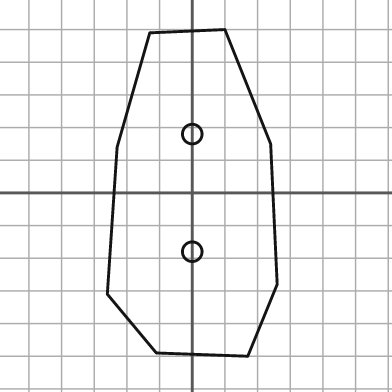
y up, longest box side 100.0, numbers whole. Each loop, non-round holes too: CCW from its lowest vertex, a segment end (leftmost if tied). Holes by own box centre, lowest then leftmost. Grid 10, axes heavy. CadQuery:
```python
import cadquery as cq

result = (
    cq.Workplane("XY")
    .moveTo(17.0, -50.0)
    .lineTo(26.0, -28.0)
    .lineTo(24.0, 15.0)
    .lineTo(10.0, 50.0)
    .lineTo(-13.0, 49.0)
    .lineTo(-23.0, 14.0)
    .lineTo(-26.0, -31.0)
    .lineTo(-11.0, -49.0)
    .close()
    .moveTo(0.0, -18.0)
    .circle(3.0)
    .moveTo(0.0, 18.0)
    .circle(3.0)
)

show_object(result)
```